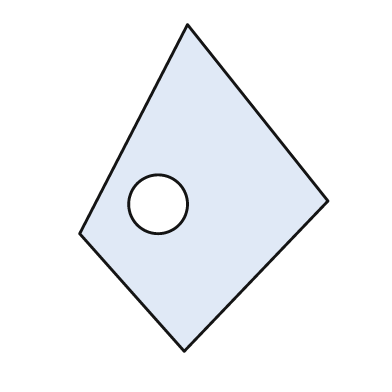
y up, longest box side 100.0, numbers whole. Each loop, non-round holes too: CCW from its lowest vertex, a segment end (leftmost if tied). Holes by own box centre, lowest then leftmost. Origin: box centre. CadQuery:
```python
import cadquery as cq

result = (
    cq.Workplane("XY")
    .moveTo(-6.0, -50.0)
    .lineTo(38.0, -4.0)
    .lineTo(-5.0, 50.0)
    .lineTo(-38.0, -14.0)
    .close()
    .moveTo(-14.0, -5.0)
    .circle(9.0)
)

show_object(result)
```